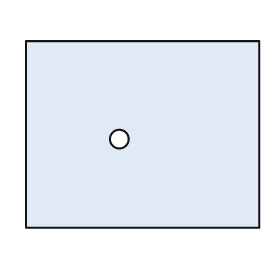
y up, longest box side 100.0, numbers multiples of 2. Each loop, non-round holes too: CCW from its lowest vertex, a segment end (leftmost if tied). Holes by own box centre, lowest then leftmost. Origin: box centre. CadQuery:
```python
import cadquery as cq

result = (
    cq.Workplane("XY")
    .moveTo(-50.0, -40.0)
    .lineTo(50.0, -40.0)
    .lineTo(50.0, 40.0)
    .lineTo(-50.0, 40.0)
    .close()
    .moveTo(-10.0, -2.0)
    .circle(4.0)
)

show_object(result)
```